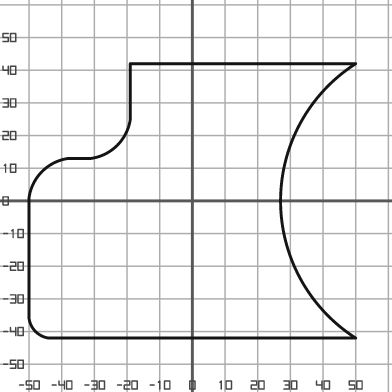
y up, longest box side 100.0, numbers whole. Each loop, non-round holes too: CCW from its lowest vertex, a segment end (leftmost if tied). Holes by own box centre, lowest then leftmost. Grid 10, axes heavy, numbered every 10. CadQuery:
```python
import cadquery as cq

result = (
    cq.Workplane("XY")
    .moveTo(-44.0, -42.0)
    .lineTo(50.0, -42.0)
    .threePointArc((27.0, 0.0), (50.0, 42.0))
    .lineTo(-19.0, 42.0)
    .lineTo(-19.0, 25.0)
    .threePointArc((-23.0, 17.0), (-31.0, 13.0))
    .lineTo(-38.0, 13.0)
    .threePointArc((-46.0, 9.0), (-50.0, 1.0))
    .lineTo(-50.0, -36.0)
    .threePointArc((-48.0, -40.0), (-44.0, -42.0))
    .close()
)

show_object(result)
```